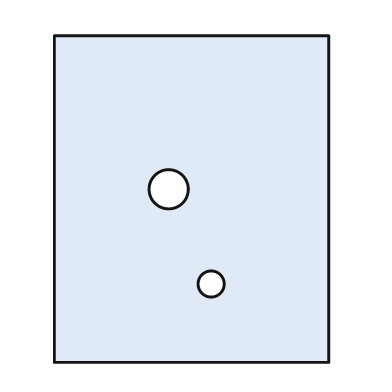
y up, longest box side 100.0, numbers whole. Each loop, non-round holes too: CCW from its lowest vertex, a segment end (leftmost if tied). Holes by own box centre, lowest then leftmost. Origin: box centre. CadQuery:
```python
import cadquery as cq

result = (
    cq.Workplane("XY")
    .moveTo(-42.0, -50.0)
    .lineTo(42.0, -50.0)
    .lineTo(42.0, 50.0)
    .lineTo(-42.0, 50.0)
    .close()
    .moveTo(6.0, -26.0)
    .circle(4.0)
    .moveTo(-7.0, 3.0)
    .circle(6.0)
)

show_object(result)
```